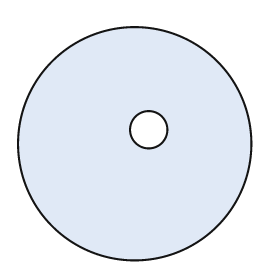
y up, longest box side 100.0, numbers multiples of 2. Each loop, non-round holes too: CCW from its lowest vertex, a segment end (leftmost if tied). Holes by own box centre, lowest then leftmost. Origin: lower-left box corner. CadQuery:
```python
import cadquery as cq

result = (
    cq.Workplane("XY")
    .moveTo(50.0, 50.0)
    .circle(50.0)
    .moveTo(56.0, 56.0)
    .circle(8.0)
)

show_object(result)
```